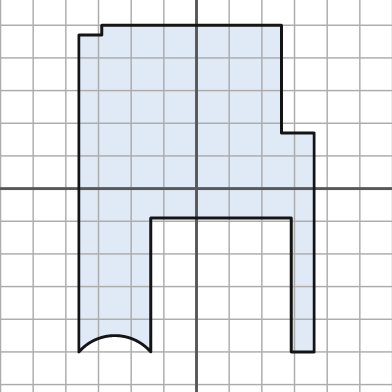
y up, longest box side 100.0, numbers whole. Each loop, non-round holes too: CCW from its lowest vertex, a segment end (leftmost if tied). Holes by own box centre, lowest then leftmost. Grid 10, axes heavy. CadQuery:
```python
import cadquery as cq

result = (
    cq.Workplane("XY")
    .moveTo(-36.0, -50.0)
    .threePointArc((-25.0, -45.0), (-14.0, -50.0))
    .lineTo(-14.0, -9.0)
    .lineTo(29.0, -9.0)
    .lineTo(29.0, -50.0)
    .lineTo(36.0, -50.0)
    .lineTo(36.0, 17.0)
    .lineTo(26.0, 17.0)
    .lineTo(26.0, 50.0)
    .lineTo(-29.0, 50.0)
    .lineTo(-29.0, 47.0)
    .lineTo(-36.0, 47.0)
    .close()
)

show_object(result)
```